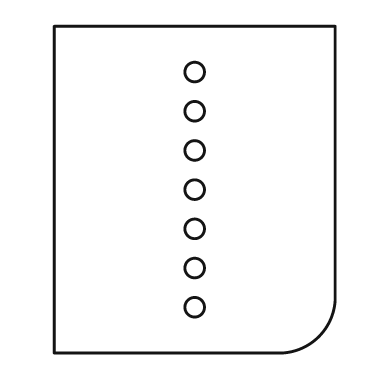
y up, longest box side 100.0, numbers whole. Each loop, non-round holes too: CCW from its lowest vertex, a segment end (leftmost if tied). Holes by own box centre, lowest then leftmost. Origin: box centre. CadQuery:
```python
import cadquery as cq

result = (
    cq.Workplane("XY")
    .moveTo(-43.0, -50.0)
    .lineTo(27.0, -50.0)
    .threePointArc((38.0, -45.0), (43.0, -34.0))
    .lineTo(43.0, 50.0)
    .lineTo(-43.0, 50.0)
    .close()
    .moveTo(0.0, -36.0)
    .circle(3.0)
    .moveTo(0.0, -24.0)
    .circle(3.0)
    .moveTo(0.0, -12.0)
    .circle(3.0)
    .moveTo(0.0, 0.0)
    .circle(3.0)
    .moveTo(0.0, 12.0)
    .circle(3.0)
    .moveTo(0.0, 24.0)
    .circle(3.0)
    .moveTo(0.0, 36.0)
    .circle(3.0)
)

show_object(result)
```